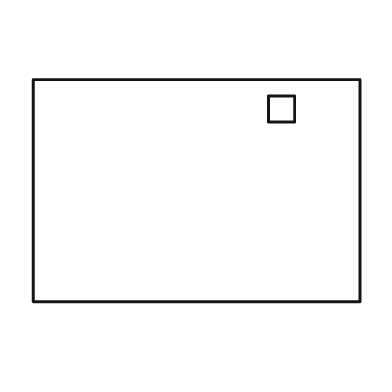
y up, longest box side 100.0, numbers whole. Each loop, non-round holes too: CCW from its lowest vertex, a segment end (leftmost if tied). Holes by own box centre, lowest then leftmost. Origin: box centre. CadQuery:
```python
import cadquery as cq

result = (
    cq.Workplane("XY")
    .moveTo(-50.0, -34.0)
    .lineTo(50.0, -34.0)
    .lineTo(50.0, 34.0)
    .lineTo(-50.0, 34.0)
    .close()
    .moveTo(22.0, 21.0)
    .lineTo(30.0, 21.0)
    .lineTo(30.0, 29.0)
    .lineTo(22.0, 29.0)
    .close()
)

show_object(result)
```